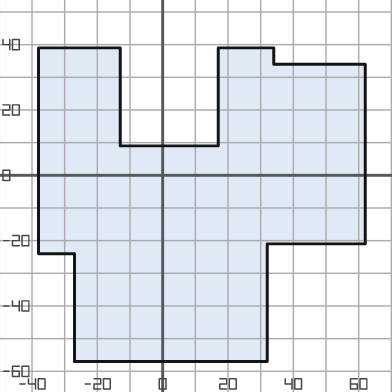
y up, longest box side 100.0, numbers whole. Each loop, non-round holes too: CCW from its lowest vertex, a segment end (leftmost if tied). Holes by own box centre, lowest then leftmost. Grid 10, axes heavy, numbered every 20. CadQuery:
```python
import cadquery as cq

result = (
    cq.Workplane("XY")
    .moveTo(-27.0, -57.0)
    .lineTo(32.0, -57.0)
    .lineTo(32.0, -21.0)
    .lineTo(62.0, -21.0)
    .lineTo(62.0, 34.0)
    .lineTo(34.0, 34.0)
    .lineTo(34.0, 39.0)
    .lineTo(17.0, 39.0)
    .lineTo(17.0, 9.0)
    .lineTo(-13.0, 9.0)
    .lineTo(-13.0, 39.0)
    .lineTo(-38.0, 39.0)
    .lineTo(-38.0, -24.0)
    .lineTo(-27.0, -24.0)
    .close()
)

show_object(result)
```